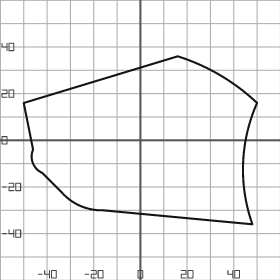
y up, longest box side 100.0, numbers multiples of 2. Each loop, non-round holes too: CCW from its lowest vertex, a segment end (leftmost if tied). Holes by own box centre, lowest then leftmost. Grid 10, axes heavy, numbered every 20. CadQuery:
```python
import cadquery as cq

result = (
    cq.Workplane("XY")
    .moveTo(48.0, -36.0)
    .threePointArc((44.0, -10.0), (50.0, 16.0))
    .threePointArc((34.0, 28.0), (16.0, 36.0))
    .lineTo(-50.0, 16.0)
    .lineTo(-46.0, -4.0)
    .threePointArc((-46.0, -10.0), (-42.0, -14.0))
    .lineTo(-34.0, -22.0)
    .threePointArc((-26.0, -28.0), (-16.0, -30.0))
    .close()
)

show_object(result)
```